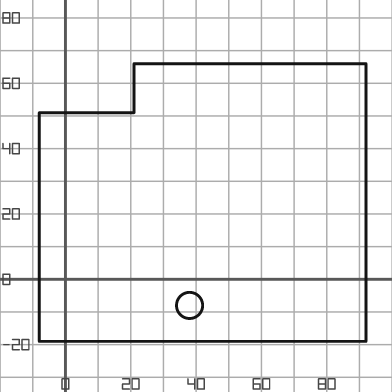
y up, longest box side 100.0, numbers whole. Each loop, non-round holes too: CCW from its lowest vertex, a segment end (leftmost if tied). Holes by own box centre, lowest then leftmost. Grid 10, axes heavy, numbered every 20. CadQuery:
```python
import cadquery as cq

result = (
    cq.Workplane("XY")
    .moveTo(-8.0, -19.0)
    .lineTo(92.0, -19.0)
    .lineTo(92.0, 66.0)
    .lineTo(21.0, 66.0)
    .lineTo(21.0, 51.0)
    .lineTo(-8.0, 51.0)
    .close()
    .moveTo(38.0, -8.0)
    .circle(4.0)
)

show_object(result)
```